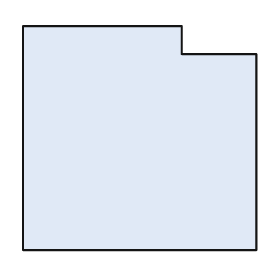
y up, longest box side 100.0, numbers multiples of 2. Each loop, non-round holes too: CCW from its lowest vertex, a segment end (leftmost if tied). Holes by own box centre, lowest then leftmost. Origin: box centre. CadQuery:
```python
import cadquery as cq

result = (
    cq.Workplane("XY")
    .moveTo(-50.0, -48.0)
    .lineTo(50.0, -48.0)
    .lineTo(50.0, 36.0)
    .lineTo(18.0, 36.0)
    .lineTo(18.0, 48.0)
    .lineTo(-50.0, 48.0)
    .close()
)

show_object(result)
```